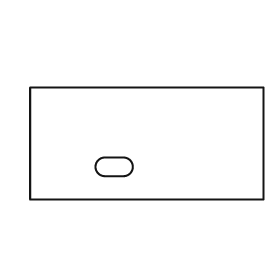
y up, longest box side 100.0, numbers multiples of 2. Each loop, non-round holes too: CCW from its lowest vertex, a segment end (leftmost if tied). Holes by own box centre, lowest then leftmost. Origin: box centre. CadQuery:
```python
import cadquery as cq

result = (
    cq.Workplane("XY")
    .moveTo(-50.0, -24.0)
    .lineTo(50.0, -24.0)
    .lineTo(50.0, 24.0)
    .lineTo(-50.0, 24.0)
    .close()
    .moveTo(-18.0, -14.0)
    .lineTo(-10.0, -14.0)
    .threePointArc((-6.0, -10.0), (-10.0, -6.0))
    .lineTo(-18.0, -6.0)
    .threePointArc((-22.0, -10.0), (-18.0, -14.0))
    .close()
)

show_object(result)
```